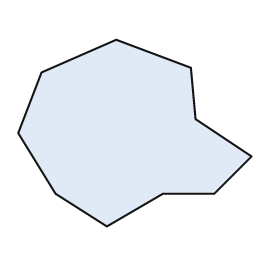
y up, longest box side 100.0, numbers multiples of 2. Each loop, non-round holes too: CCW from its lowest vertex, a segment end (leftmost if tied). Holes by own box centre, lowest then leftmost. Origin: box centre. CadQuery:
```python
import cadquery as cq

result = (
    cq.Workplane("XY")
    .moveTo(-12.0, -40.0)
    .lineTo(12.0, -26.0)
    .lineTo(34.0, -26.0)
    .lineTo(50.0, -10.0)
    .lineTo(26.0, 6.0)
    .lineTo(24.0, 28.0)
    .lineTo(-8.0, 40.0)
    .lineTo(-40.0, 26.0)
    .lineTo(-50.0, 0.0)
    .lineTo(-34.0, -26.0)
    .close()
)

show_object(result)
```